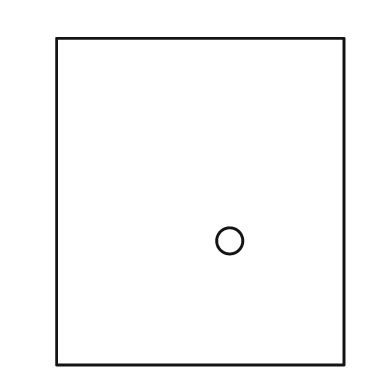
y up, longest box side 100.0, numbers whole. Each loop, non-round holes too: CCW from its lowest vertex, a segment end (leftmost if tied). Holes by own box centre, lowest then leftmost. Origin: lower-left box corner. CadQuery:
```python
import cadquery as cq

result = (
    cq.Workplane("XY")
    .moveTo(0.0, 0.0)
    .lineTo(88.0, 0.0)
    .lineTo(88.0, 100.0)
    .lineTo(0.0, 100.0)
    .close()
    .moveTo(53.0, 38.0)
    .circle(4.0)
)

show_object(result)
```